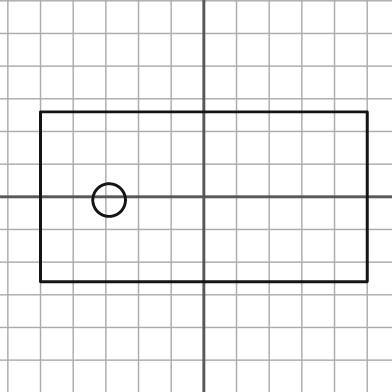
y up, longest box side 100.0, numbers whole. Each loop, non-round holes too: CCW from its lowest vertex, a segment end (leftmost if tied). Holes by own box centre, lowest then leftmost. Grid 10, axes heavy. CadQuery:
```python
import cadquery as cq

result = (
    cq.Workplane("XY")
    .moveTo(-50.0, -26.0)
    .lineTo(50.0, -26.0)
    .lineTo(50.0, 26.0)
    .lineTo(-50.0, 26.0)
    .close()
    .moveTo(-29.0, -1.0)
    .circle(5.0)
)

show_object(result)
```